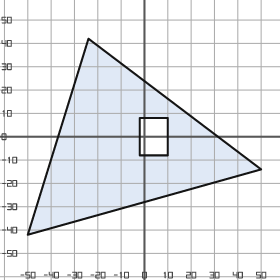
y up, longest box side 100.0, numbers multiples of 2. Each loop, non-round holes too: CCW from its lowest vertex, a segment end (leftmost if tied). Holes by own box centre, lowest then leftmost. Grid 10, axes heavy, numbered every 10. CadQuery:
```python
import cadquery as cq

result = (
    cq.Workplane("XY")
    .moveTo(-50.0, -42.0)
    .lineTo(50.0, -14.0)
    .lineTo(-24.0, 42.0)
    .close()
    .moveTo(-2.0, -8.0)
    .lineTo(10.0, -8.0)
    .lineTo(10.0, 8.0)
    .lineTo(-2.0, 8.0)
    .close()
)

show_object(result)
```